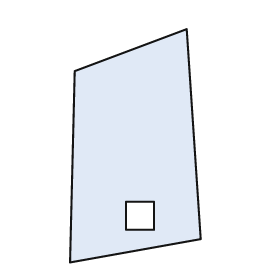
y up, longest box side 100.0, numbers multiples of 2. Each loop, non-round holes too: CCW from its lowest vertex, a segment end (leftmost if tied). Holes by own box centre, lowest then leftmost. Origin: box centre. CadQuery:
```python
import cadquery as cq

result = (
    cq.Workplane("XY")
    .moveTo(-28.0, -50.0)
    .lineTo(28.0, -40.0)
    .lineTo(22.0, 50.0)
    .lineTo(-26.0, 32.0)
    .close()
    .moveTo(-4.0, -36.0)
    .lineTo(8.0, -36.0)
    .lineTo(8.0, -24.0)
    .lineTo(-4.0, -24.0)
    .close()
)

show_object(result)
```